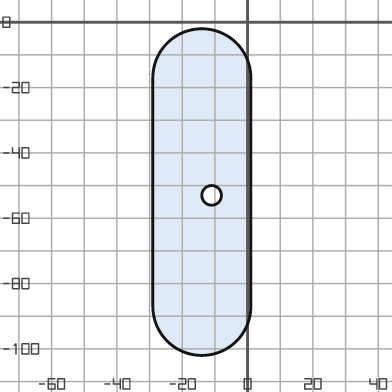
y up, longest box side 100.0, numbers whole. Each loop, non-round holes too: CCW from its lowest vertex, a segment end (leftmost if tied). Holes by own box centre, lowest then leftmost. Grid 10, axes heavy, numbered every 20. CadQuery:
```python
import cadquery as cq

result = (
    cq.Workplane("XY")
    .moveTo(-29.0, -87.0)
    .threePointArc((-14.0, -102.0), (1.0, -87.0))
    .lineTo(1.0, -17.0)
    .threePointArc((-14.0, -2.0), (-29.0, -17.0))
    .close()
    .moveTo(-11.0, -53.0)
    .circle(3.0)
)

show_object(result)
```